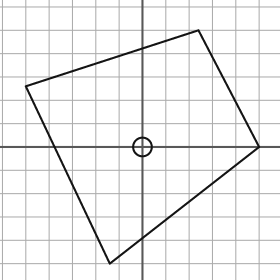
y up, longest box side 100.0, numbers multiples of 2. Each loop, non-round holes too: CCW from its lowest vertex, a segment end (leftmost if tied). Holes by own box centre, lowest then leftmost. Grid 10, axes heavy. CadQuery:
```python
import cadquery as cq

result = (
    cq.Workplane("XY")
    .moveTo(-14.0, -50.0)
    .lineTo(50.0, 0.0)
    .lineTo(24.0, 50.0)
    .lineTo(-50.0, 26.0)
    .close()
    .moveTo(0.0, 0.0)
    .circle(4.0)
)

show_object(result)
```